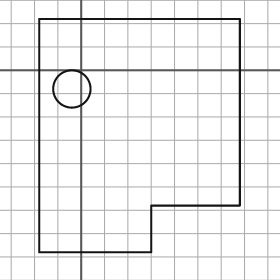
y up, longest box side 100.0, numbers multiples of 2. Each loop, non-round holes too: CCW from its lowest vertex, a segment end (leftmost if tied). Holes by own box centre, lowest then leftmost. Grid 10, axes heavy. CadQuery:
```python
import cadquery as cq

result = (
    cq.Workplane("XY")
    .moveTo(-18.0, -78.0)
    .lineTo(30.0, -78.0)
    .lineTo(30.0, -58.0)
    .lineTo(68.0, -58.0)
    .lineTo(68.0, 22.0)
    .lineTo(-18.0, 22.0)
    .close()
    .moveTo(-4.0, -8.0)
    .circle(8.0)
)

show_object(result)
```